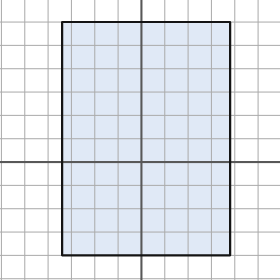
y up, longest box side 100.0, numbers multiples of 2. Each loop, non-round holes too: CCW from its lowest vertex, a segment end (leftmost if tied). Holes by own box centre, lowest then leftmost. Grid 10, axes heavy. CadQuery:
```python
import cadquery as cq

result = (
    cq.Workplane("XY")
    .moveTo(-34.0, -40.0)
    .lineTo(38.0, -40.0)
    .lineTo(38.0, 60.0)
    .lineTo(-34.0, 60.0)
    .close()
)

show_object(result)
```